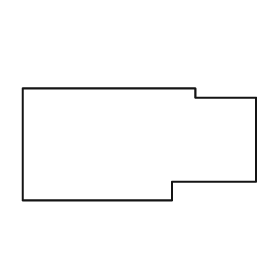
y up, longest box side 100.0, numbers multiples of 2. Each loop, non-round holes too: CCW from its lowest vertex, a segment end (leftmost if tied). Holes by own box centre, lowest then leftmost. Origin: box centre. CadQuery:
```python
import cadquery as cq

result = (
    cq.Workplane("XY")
    .moveTo(-50.0, -24.0)
    .lineTo(14.0, -24.0)
    .lineTo(14.0, -16.0)
    .lineTo(50.0, -16.0)
    .lineTo(50.0, 20.0)
    .lineTo(24.0, 20.0)
    .lineTo(24.0, 24.0)
    .lineTo(-50.0, 24.0)
    .close()
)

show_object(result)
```